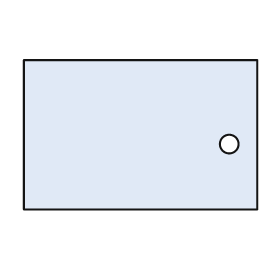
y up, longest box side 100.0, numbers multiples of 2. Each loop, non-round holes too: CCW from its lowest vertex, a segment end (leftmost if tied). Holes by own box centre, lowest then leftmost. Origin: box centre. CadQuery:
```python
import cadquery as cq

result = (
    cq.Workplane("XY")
    .moveTo(-50.0, -32.0)
    .lineTo(50.0, -32.0)
    .lineTo(50.0, 32.0)
    .lineTo(-50.0, 32.0)
    .close()
    .moveTo(38.0, -4.0)
    .circle(4.0)
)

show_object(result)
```